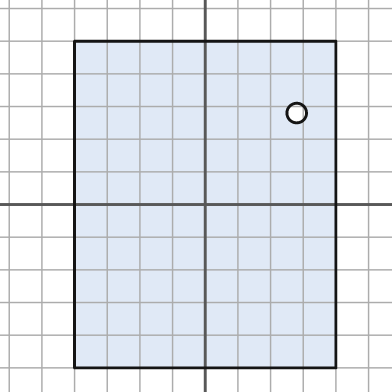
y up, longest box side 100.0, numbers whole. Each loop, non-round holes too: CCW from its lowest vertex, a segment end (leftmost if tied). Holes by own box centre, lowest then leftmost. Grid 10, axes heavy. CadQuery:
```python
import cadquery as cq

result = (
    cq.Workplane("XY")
    .moveTo(-40.0, -50.0)
    .lineTo(40.0, -50.0)
    .lineTo(40.0, 50.0)
    .lineTo(-40.0, 50.0)
    .close()
    .moveTo(28.0, 28.0)
    .circle(3.0)
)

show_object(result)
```